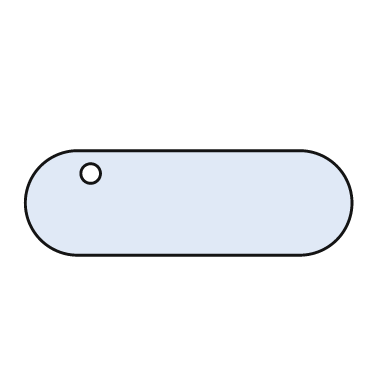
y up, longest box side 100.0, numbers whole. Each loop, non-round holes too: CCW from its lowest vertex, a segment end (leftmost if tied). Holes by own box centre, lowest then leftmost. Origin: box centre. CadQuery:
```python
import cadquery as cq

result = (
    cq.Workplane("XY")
    .moveTo(-34.0, -16.0)
    .lineTo(34.0, -16.0)
    .threePointArc((50.0, 0.0), (34.0, 16.0))
    .lineTo(-34.0, 16.0)
    .threePointArc((-50.0, 0.0), (-34.0, -16.0))
    .close()
    .moveTo(-30.0, 9.0)
    .circle(3.0)
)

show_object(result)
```